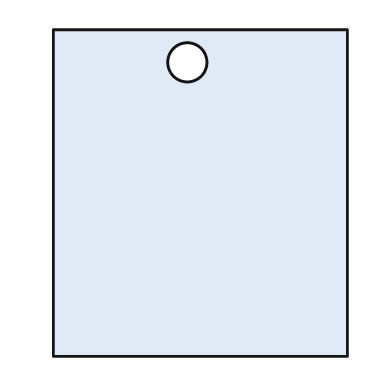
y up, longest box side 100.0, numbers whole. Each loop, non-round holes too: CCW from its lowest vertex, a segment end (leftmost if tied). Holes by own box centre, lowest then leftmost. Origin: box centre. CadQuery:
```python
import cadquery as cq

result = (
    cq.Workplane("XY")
    .moveTo(-45.0, -50.0)
    .lineTo(45.0, -50.0)
    .lineTo(45.0, 50.0)
    .lineTo(-45.0, 50.0)
    .close()
    .moveTo(-4.0, 40.0)
    .circle(6.0)
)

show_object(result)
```